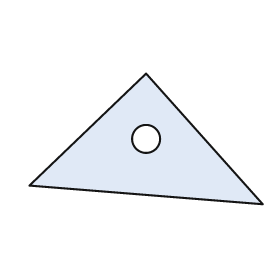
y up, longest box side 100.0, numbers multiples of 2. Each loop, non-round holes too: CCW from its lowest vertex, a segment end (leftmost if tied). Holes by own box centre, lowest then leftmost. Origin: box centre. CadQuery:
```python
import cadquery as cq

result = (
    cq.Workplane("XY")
    .moveTo(50.0, -28.0)
    .lineTo(0.0, 28.0)
    .lineTo(-50.0, -20.0)
    .close()
    .moveTo(0.0, 0.0)
    .circle(6.0)
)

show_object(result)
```